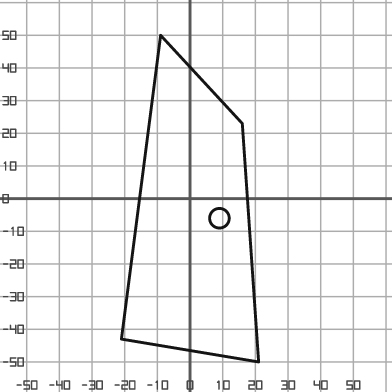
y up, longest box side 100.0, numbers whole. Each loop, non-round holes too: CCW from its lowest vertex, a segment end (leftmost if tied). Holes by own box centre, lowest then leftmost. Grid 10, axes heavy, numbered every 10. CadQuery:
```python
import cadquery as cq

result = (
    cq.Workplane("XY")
    .moveTo(21.0, -50.0)
    .lineTo(16.0, 23.0)
    .lineTo(-9.0, 50.0)
    .lineTo(-21.0, -43.0)
    .close()
    .moveTo(9.0, -6.0)
    .circle(3.0)
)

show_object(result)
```